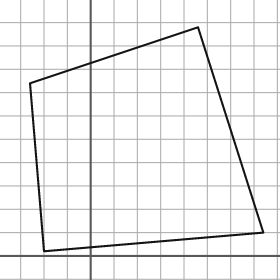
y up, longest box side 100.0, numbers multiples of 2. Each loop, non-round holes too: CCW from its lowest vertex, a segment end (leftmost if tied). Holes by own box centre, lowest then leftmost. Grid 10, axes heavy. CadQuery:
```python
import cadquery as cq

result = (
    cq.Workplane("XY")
    .moveTo(-20.0, 2.0)
    .lineTo(74.0, 10.0)
    .lineTo(46.0, 98.0)
    .lineTo(-26.0, 74.0)
    .close()
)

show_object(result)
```